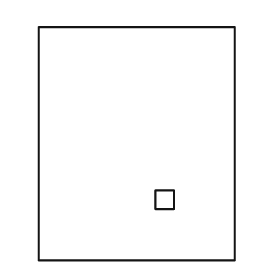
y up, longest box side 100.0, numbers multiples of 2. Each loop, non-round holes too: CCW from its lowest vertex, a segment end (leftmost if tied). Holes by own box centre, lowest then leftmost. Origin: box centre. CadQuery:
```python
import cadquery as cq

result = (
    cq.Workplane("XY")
    .moveTo(-42.0, -50.0)
    .lineTo(42.0, -50.0)
    .lineTo(42.0, 50.0)
    .lineTo(-42.0, 50.0)
    .close()
    .moveTo(8.0, -28.0)
    .lineTo(16.0, -28.0)
    .lineTo(16.0, -20.0)
    .lineTo(8.0, -20.0)
    .close()
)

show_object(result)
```